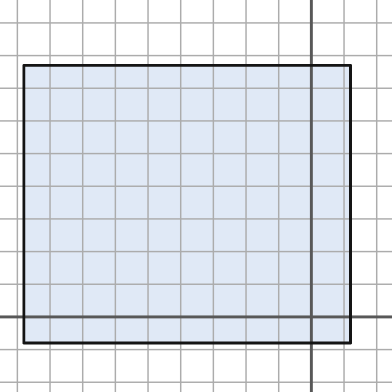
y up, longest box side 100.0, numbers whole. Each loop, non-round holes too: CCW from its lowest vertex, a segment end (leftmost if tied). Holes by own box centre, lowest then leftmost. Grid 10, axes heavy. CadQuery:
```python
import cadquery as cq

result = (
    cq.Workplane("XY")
    .moveTo(-88.0, -8.0)
    .lineTo(12.0, -8.0)
    .lineTo(12.0, 77.0)
    .lineTo(-88.0, 77.0)
    .close()
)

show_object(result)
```